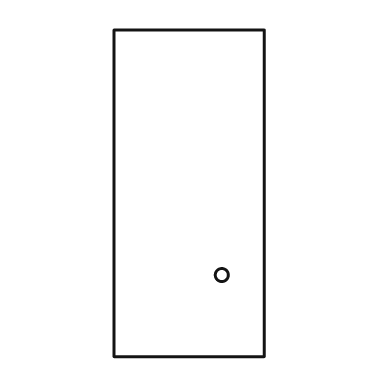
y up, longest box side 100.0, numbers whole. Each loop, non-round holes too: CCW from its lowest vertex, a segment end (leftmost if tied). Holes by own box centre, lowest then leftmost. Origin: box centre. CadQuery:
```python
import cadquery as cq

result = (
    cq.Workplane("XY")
    .moveTo(-23.0, -50.0)
    .lineTo(23.0, -50.0)
    .lineTo(23.0, 50.0)
    .lineTo(-23.0, 50.0)
    .close()
    .moveTo(10.0, -25.0)
    .circle(2.0)
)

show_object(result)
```